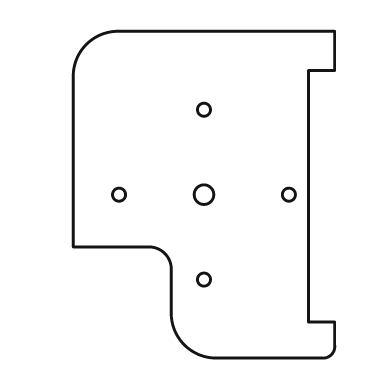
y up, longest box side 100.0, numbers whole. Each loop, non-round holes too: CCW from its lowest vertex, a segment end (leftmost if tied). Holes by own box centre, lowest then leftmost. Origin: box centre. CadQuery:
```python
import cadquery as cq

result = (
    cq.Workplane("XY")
    .moveTo(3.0, -50.0)
    .lineTo(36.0, -50.0)
    .threePointArc((39.0, -49.0), (40.0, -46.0))
    .lineTo(40.0, -39.0)
    .lineTo(32.0, -39.0)
    .lineTo(32.0, 38.0)
    .lineTo(40.0, 38.0)
    .lineTo(40.0, 50.0)
    .lineTo(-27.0, 50.0)
    .threePointArc((-36.0, 46.0), (-40.0, 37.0))
    .lineTo(-40.0, -16.0)
    .lineTo(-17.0, -16.0)
    .threePointArc((-12.0, -18.0), (-10.0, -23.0))
    .lineTo(-10.0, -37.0)
    .threePointArc((-6.0, -46.0), (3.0, -50.0))
    .close()
    .moveTo(0.0, -26.0)
    .circle(2.0)
    .moveTo(-26.0, 0.0)
    .circle(2.0)
    .moveTo(0.0, 0.0)
    .circle(3.0)
    .moveTo(26.0, 0.0)
    .circle(2.0)
    .moveTo(0.0, 26.0)
    .circle(2.0)
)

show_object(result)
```